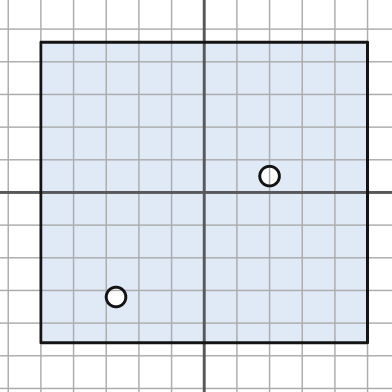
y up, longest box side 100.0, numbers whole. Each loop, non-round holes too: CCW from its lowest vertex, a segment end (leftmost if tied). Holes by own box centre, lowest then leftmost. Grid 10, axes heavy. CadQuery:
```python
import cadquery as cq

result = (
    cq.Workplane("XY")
    .moveTo(-50.0, -46.0)
    .lineTo(50.0, -46.0)
    .lineTo(50.0, 46.0)
    .lineTo(-50.0, 46.0)
    .close()
    .moveTo(-27.0, -32.0)
    .circle(3.0)
    .moveTo(20.0, 5.0)
    .circle(3.0)
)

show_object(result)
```